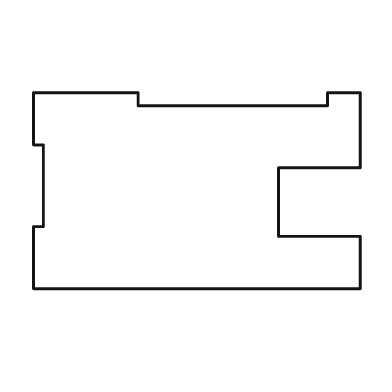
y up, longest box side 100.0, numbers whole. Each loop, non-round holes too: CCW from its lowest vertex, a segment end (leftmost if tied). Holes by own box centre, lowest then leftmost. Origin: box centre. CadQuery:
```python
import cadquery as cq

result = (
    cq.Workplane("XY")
    .moveTo(-50.0, -30.0)
    .lineTo(50.0, -30.0)
    .lineTo(50.0, -14.0)
    .lineTo(25.0, -14.0)
    .lineTo(25.0, 7.0)
    .lineTo(50.0, 7.0)
    .lineTo(50.0, 30.0)
    .lineTo(40.0, 30.0)
    .lineTo(40.0, 26.0)
    .lineTo(-18.0, 26.0)
    .lineTo(-18.0, 30.0)
    .lineTo(-50.0, 30.0)
    .lineTo(-50.0, 14.0)
    .lineTo(-47.0, 14.0)
    .lineTo(-47.0, -11.0)
    .lineTo(-50.0, -11.0)
    .close()
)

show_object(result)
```